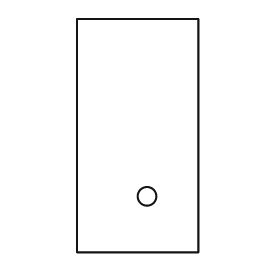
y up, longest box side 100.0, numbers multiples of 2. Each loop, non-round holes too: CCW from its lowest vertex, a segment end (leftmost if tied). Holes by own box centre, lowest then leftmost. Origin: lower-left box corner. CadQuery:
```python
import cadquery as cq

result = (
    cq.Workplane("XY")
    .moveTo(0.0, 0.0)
    .lineTo(52.0, 0.0)
    .lineTo(52.0, 100.0)
    .lineTo(0.0, 100.0)
    .close()
    .moveTo(30.0, 24.0)
    .circle(4.0)
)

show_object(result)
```